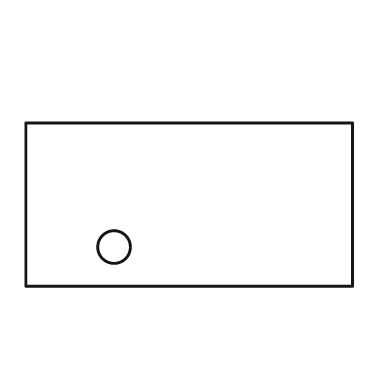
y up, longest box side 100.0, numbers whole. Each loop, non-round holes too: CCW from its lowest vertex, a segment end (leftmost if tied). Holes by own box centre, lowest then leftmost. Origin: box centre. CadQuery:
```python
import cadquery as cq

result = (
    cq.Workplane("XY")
    .moveTo(-50.0, -25.0)
    .lineTo(50.0, -25.0)
    .lineTo(50.0, 25.0)
    .lineTo(-50.0, 25.0)
    .close()
    .moveTo(-23.0, -13.0)
    .circle(5.0)
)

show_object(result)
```